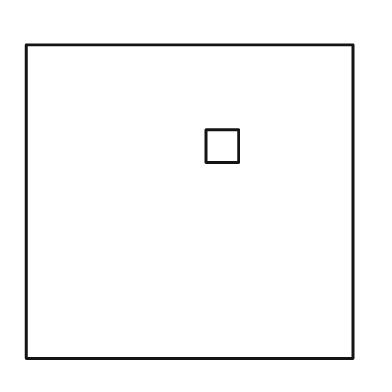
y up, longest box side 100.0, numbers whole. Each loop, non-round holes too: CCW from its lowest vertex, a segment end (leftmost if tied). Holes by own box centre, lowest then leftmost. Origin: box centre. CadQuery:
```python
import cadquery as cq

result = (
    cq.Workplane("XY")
    .moveTo(-50.0, -48.0)
    .lineTo(50.0, -48.0)
    .lineTo(50.0, 48.0)
    .lineTo(-50.0, 48.0)
    .close()
    .moveTo(5.0, 12.0)
    .lineTo(15.0, 12.0)
    .lineTo(15.0, 22.0)
    .lineTo(5.0, 22.0)
    .close()
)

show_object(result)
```